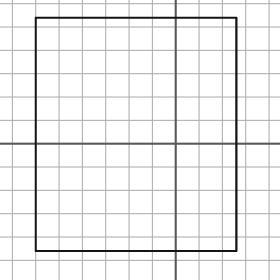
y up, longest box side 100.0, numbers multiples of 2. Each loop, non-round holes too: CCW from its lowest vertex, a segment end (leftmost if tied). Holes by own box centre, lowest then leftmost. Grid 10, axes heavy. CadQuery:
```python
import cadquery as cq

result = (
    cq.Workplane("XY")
    .moveTo(-60.0, -46.0)
    .lineTo(26.0, -46.0)
    .lineTo(26.0, 54.0)
    .lineTo(-60.0, 54.0)
    .close()
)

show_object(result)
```